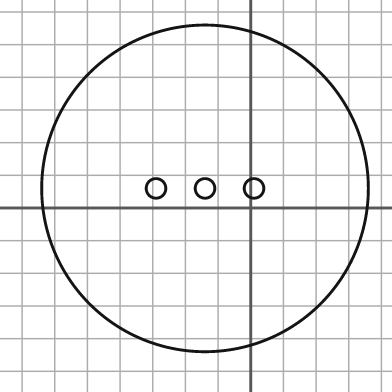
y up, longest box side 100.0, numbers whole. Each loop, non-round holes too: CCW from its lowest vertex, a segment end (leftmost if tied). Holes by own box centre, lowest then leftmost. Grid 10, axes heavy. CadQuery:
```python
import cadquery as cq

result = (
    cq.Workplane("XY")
    .moveTo(-14.0, 6.0)
    .circle(50.0)
    .moveTo(-29.0, 6.0)
    .circle(3.0)
    .moveTo(-14.0, 6.0)
    .circle(3.0)
    .moveTo(1.0, 6.0)
    .circle(3.0)
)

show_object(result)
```